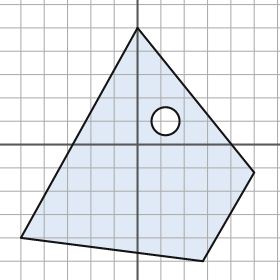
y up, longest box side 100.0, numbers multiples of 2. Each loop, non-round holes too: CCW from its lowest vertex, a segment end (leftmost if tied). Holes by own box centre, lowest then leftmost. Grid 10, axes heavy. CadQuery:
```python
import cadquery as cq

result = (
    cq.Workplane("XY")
    .moveTo(28.0, -50.0)
    .lineTo(50.0, -12.0)
    .lineTo(0.0, 50.0)
    .lineTo(-50.0, -40.0)
    .close()
    .moveTo(12.0, 10.0)
    .circle(6.0)
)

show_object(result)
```